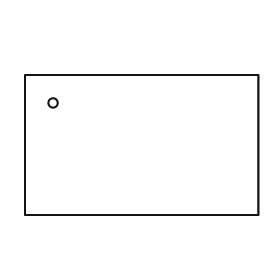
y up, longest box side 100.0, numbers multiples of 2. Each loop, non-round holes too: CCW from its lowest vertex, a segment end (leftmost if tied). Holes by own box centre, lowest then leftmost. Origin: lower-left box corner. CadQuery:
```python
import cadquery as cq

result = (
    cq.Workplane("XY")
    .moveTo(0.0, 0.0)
    .lineTo(100.0, 0.0)
    .lineTo(100.0, 60.0)
    .lineTo(0.0, 60.0)
    .close()
    .moveTo(12.0, 48.0)
    .circle(2.0)
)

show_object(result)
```